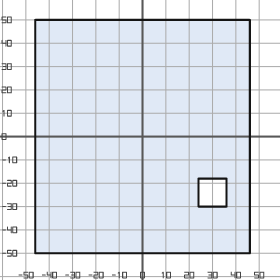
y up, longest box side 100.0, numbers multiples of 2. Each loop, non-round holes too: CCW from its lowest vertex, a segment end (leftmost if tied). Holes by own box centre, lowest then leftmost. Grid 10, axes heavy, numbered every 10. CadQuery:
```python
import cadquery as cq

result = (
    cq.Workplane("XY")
    .moveTo(-46.0, -50.0)
    .lineTo(46.0, -50.0)
    .lineTo(46.0, 50.0)
    .lineTo(-46.0, 50.0)
    .close()
    .moveTo(24.0, -30.0)
    .lineTo(36.0, -30.0)
    .lineTo(36.0, -18.0)
    .lineTo(24.0, -18.0)
    .close()
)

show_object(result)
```